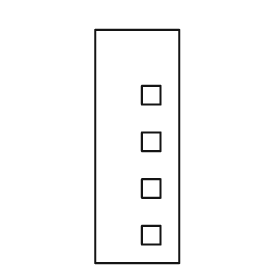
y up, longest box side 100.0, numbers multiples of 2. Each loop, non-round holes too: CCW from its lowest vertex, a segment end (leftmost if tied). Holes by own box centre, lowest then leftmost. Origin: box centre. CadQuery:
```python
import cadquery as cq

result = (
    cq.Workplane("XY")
    .moveTo(-18.0, -50.0)
    .lineTo(18.0, -50.0)
    .lineTo(18.0, 50.0)
    .lineTo(-18.0, 50.0)
    .close()
    .moveTo(2.0, -42.0)
    .lineTo(10.0, -42.0)
    .lineTo(10.0, -34.0)
    .lineTo(2.0, -34.0)
    .close()
    .moveTo(2.0, -22.0)
    .lineTo(10.0, -22.0)
    .lineTo(10.0, -14.0)
    .lineTo(2.0, -14.0)
    .close()
    .moveTo(2.0, -2.0)
    .lineTo(10.0, -2.0)
    .lineTo(10.0, 6.0)
    .lineTo(2.0, 6.0)
    .close()
    .moveTo(2.0, 18.0)
    .lineTo(10.0, 18.0)
    .lineTo(10.0, 26.0)
    .lineTo(2.0, 26.0)
    .close()
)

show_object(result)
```